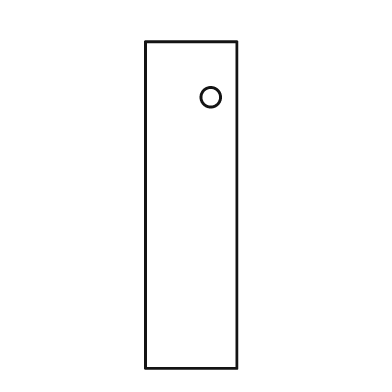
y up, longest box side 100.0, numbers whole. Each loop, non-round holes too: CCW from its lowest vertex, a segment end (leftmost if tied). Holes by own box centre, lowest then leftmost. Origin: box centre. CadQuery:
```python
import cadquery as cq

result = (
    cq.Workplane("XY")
    .moveTo(-14.0, -50.0)
    .lineTo(14.0, -50.0)
    .lineTo(14.0, 50.0)
    .lineTo(-14.0, 50.0)
    .close()
    .moveTo(6.0, 33.0)
    .circle(3.0)
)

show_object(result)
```